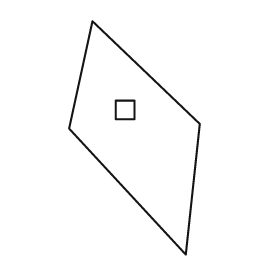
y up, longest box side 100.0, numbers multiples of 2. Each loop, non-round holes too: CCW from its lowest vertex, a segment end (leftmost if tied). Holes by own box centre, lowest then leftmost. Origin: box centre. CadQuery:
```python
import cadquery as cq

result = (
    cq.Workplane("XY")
    .moveTo(22.0, -50.0)
    .lineTo(28.0, 6.0)
    .lineTo(-18.0, 50.0)
    .lineTo(-28.0, 4.0)
    .close()
    .moveTo(-8.0, 8.0)
    .lineTo(0.0, 8.0)
    .lineTo(0.0, 16.0)
    .lineTo(-8.0, 16.0)
    .close()
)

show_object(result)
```